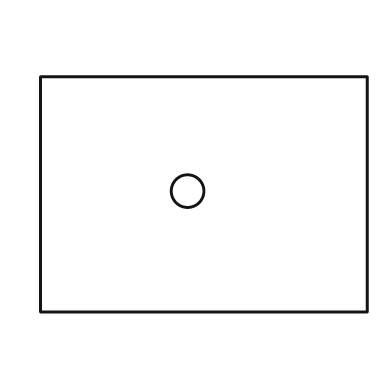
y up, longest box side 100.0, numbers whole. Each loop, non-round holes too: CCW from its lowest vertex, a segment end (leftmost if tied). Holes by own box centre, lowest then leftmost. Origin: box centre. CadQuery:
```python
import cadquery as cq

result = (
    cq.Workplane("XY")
    .moveTo(-50.0, -36.0)
    .lineTo(50.0, -36.0)
    .lineTo(50.0, 36.0)
    .lineTo(-50.0, 36.0)
    .close()
    .moveTo(-5.0, 1.0)
    .circle(5.0)
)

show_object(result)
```